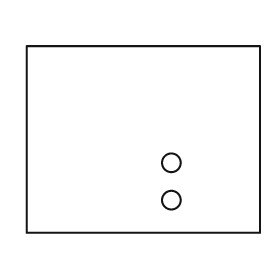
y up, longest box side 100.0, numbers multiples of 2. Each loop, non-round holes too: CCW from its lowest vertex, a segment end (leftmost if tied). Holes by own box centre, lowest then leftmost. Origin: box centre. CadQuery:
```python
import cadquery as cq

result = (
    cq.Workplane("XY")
    .moveTo(-50.0, -40.0)
    .lineTo(50.0, -40.0)
    .lineTo(50.0, 40.0)
    .lineTo(-50.0, 40.0)
    .close()
    .moveTo(12.0, -26.0)
    .circle(4.0)
    .moveTo(12.0, -10.0)
    .circle(4.0)
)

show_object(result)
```